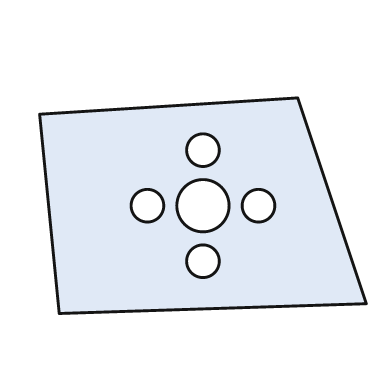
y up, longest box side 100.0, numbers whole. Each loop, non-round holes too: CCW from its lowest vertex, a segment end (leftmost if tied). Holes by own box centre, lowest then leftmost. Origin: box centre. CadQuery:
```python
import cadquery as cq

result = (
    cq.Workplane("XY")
    .moveTo(-44.0, -33.0)
    .lineTo(50.0, -30.0)
    .lineTo(29.0, 33.0)
    .lineTo(-50.0, 28.0)
    .close()
    .moveTo(0.0, -17.0)
    .circle(5.0)
    .moveTo(-17.0, 0.0)
    .circle(5.0)
    .moveTo(0.0, 0.0)
    .circle(8.0)
    .moveTo(17.0, 0.0)
    .circle(5.0)
    .moveTo(0.0, 17.0)
    .circle(5.0)
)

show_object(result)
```